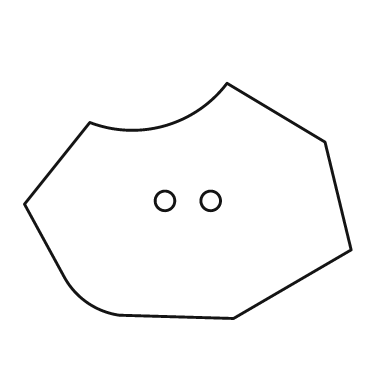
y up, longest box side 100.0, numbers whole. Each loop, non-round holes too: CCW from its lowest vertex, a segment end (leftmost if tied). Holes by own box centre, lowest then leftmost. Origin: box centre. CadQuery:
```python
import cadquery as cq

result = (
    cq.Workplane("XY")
    .moveTo(14.0, -36.0)
    .lineTo(50.0, -15.0)
    .lineTo(42.0, 18.0)
    .lineTo(12.0, 36.0)
    .threePointArc((-7.0, 23.0), (-30.0, 24.0))
    .lineTo(-50.0, -1.0)
    .lineTo(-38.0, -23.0)
    .threePointArc((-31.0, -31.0), (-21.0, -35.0))
    .close()
    .moveTo(-7.0, 0.0)
    .circle(3.0)
    .moveTo(7.0, 0.0)
    .circle(3.0)
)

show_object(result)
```